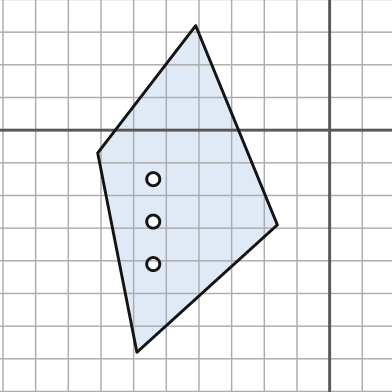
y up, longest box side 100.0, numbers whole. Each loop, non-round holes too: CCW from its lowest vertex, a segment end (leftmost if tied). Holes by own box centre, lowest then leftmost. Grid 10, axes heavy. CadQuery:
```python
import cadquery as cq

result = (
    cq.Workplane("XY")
    .moveTo(-59.0, -68.0)
    .lineTo(-16.0, -29.0)
    .lineTo(-41.0, 32.0)
    .lineTo(-71.0, -7.0)
    .close()
    .moveTo(-54.0, -41.0)
    .circle(2.0)
    .moveTo(-54.0, -28.0)
    .circle(2.0)
    .moveTo(-54.0, -15.0)
    .circle(2.0)
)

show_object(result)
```